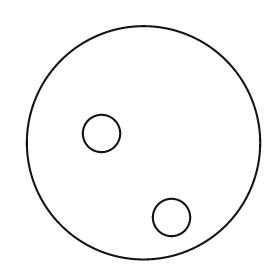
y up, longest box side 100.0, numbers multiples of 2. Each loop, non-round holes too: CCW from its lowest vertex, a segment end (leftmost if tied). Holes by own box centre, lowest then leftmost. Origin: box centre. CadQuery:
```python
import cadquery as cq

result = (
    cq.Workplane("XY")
    .moveTo(0.0, 0.0)
    .circle(50.0)
    .moveTo(12.0, -32.0)
    .circle(8.0)
    .moveTo(-18.0, 4.0)
    .circle(8.0)
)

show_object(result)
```